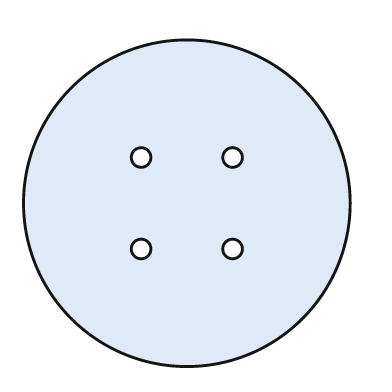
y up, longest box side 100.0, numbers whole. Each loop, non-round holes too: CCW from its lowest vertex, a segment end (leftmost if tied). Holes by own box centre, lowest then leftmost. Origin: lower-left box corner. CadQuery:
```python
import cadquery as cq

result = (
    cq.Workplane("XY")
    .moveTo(50.0, 50.0)
    .circle(50.0)
    .moveTo(36.0, 36.0)
    .circle(3.0)
    .moveTo(64.0, 36.0)
    .circle(3.0)
    .moveTo(36.0, 64.0)
    .circle(3.0)
    .moveTo(64.0, 64.0)
    .circle(3.0)
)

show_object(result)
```